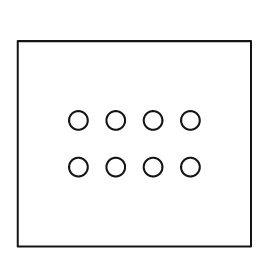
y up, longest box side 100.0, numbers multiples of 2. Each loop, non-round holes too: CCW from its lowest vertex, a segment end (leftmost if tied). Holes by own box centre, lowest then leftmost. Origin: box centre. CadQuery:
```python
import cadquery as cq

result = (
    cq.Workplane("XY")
    .moveTo(-50.0, -44.0)
    .lineTo(50.0, -44.0)
    .lineTo(50.0, 44.0)
    .lineTo(-50.0, 44.0)
    .close()
    .moveTo(-24.0, -10.0)
    .circle(4.0)
    .moveTo(-8.0, -10.0)
    .circle(4.0)
    .moveTo(8.0, -10.0)
    .circle(4.0)
    .moveTo(24.0, -10.0)
    .circle(4.0)
    .moveTo(-24.0, 10.0)
    .circle(4.0)
    .moveTo(-8.0, 10.0)
    .circle(4.0)
    .moveTo(8.0, 10.0)
    .circle(4.0)
    .moveTo(24.0, 10.0)
    .circle(4.0)
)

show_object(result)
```